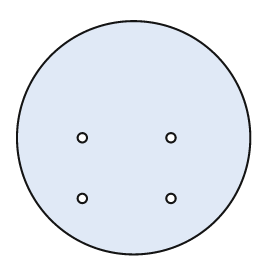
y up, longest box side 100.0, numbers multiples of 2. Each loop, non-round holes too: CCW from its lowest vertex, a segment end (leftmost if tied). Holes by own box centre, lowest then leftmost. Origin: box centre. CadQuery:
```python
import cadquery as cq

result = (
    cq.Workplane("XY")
    .moveTo(0.0, 0.0)
    .circle(50.0)
    .moveTo(-22.0, -26.0)
    .circle(2.0)
    .moveTo(16.0, -26.0)
    .circle(2.0)
    .moveTo(-22.0, 0.0)
    .circle(2.0)
    .moveTo(16.0, 0.0)
    .circle(2.0)
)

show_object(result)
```